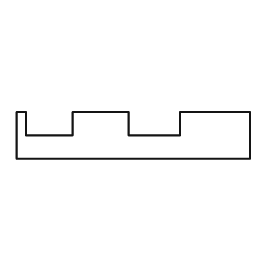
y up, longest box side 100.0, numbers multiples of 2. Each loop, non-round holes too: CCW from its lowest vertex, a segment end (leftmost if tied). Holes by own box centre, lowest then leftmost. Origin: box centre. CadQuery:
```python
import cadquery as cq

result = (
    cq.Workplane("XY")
    .moveTo(-50.0, -10.0)
    .lineTo(50.0, -10.0)
    .lineTo(50.0, 10.0)
    .lineTo(20.0, 10.0)
    .lineTo(20.0, 0.0)
    .lineTo(-2.0, 0.0)
    .lineTo(-2.0, 10.0)
    .lineTo(-26.0, 10.0)
    .lineTo(-26.0, 0.0)
    .lineTo(-46.0, 0.0)
    .lineTo(-46.0, 10.0)
    .lineTo(-50.0, 10.0)
    .close()
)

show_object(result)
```